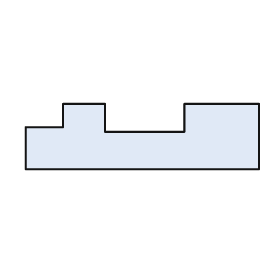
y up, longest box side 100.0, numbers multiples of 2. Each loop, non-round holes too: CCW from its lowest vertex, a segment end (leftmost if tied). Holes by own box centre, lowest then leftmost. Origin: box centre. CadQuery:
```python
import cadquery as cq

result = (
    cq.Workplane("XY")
    .moveTo(-50.0, -14.0)
    .lineTo(50.0, -14.0)
    .lineTo(50.0, 14.0)
    .lineTo(18.0, 14.0)
    .lineTo(18.0, 2.0)
    .lineTo(-16.0, 2.0)
    .lineTo(-16.0, 14.0)
    .lineTo(-34.0, 14.0)
    .lineTo(-34.0, 4.0)
    .lineTo(-50.0, 4.0)
    .close()
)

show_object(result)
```